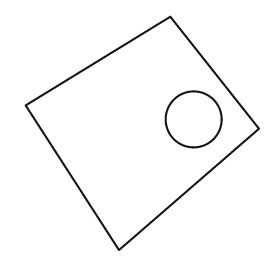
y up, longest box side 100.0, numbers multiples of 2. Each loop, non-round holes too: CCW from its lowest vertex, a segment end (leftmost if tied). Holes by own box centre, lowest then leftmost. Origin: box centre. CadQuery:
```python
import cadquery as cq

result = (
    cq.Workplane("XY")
    .moveTo(-10.0, -50.0)
    .lineTo(50.0, 2.0)
    .lineTo(12.0, 50.0)
    .lineTo(-50.0, 12.0)
    .close()
    .moveTo(22.0, 6.0)
    .circle(12.0)
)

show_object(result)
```